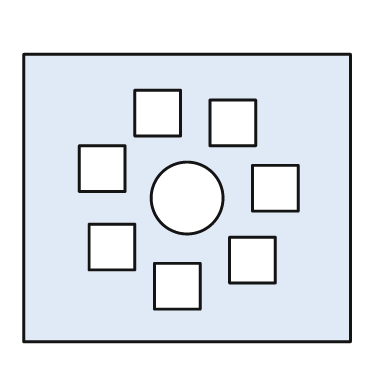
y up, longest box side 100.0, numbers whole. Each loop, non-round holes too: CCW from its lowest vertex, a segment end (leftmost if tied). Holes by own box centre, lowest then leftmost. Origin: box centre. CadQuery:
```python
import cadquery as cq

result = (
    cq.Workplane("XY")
    .moveTo(-50.0, -44.0)
    .lineTo(50.0, -44.0)
    .lineTo(50.0, 44.0)
    .lineTo(-50.0, 44.0)
    .close()
    .moveTo(-10.0, -34.0)
    .lineTo(4.0, -34.0)
    .lineTo(4.0, -20.0)
    .lineTo(-10.0, -20.0)
    .close()
    .moveTo(13.0, -26.0)
    .lineTo(27.0, -26.0)
    .lineTo(27.0, -12.0)
    .lineTo(13.0, -12.0)
    .close()
    .moveTo(-30.0, -22.0)
    .lineTo(-16.0, -22.0)
    .lineTo(-16.0, -8.0)
    .lineTo(-30.0, -8.0)
    .close()
    .moveTo(0.0, 0.0)
    .circle(11.0)
    .moveTo(20.0, -4.0)
    .lineTo(34.0, -4.0)
    .lineTo(34.0, 10.0)
    .lineTo(20.0, 10.0)
    .close()
    .moveTo(-33.0, 2.0)
    .lineTo(-19.0, 2.0)
    .lineTo(-19.0, 16.0)
    .lineTo(-33.0, 16.0)
    .close()
    .moveTo(7.0, 16.0)
    .lineTo(21.0, 16.0)
    .lineTo(21.0, 30.0)
    .lineTo(7.0, 30.0)
    .close()
    .moveTo(-16.0, 19.0)
    .lineTo(-2.0, 19.0)
    .lineTo(-2.0, 33.0)
    .lineTo(-16.0, 33.0)
    .close()
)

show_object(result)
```